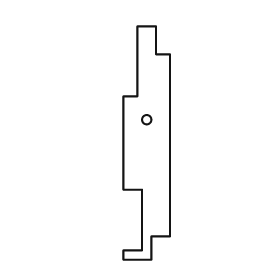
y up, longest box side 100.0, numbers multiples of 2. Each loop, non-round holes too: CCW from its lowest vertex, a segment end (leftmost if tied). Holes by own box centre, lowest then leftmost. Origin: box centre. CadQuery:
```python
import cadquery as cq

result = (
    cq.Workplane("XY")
    .moveTo(-10.0, -50.0)
    .lineTo(2.0, -50.0)
    .lineTo(2.0, -40.0)
    .lineTo(10.0, -40.0)
    .lineTo(10.0, 38.0)
    .lineTo(4.0, 38.0)
    .lineTo(4.0, 50.0)
    .lineTo(-4.0, 50.0)
    .lineTo(-4.0, 20.0)
    .lineTo(-10.0, 20.0)
    .lineTo(-10.0, -20.0)
    .lineTo(-2.0, -20.0)
    .lineTo(-2.0, -46.0)
    .lineTo(-10.0, -46.0)
    .close()
    .moveTo(0.0, 10.0)
    .circle(2.0)
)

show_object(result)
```